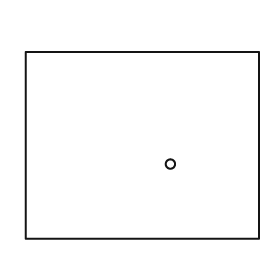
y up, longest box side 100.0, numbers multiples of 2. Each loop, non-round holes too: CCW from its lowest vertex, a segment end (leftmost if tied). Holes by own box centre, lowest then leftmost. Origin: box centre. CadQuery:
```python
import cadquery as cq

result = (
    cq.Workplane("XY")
    .moveTo(-50.0, -40.0)
    .lineTo(50.0, -40.0)
    .lineTo(50.0, 40.0)
    .lineTo(-50.0, 40.0)
    .close()
    .moveTo(12.0, -8.0)
    .circle(2.0)
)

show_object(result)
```